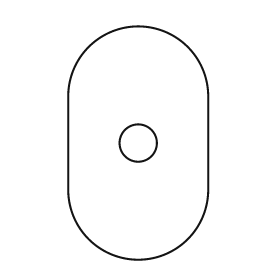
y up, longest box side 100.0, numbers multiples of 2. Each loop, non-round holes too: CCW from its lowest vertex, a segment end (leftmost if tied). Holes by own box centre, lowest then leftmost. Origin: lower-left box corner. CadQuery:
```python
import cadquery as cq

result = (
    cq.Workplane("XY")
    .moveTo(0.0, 30.0)
    .threePointArc((30.0, 0.0), (60.0, 30.0))
    .lineTo(60.0, 70.0)
    .threePointArc((30.0, 100.0), (0.0, 70.0))
    .close()
    .moveTo(30.0, 50.0)
    .circle(8.0)
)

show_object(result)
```